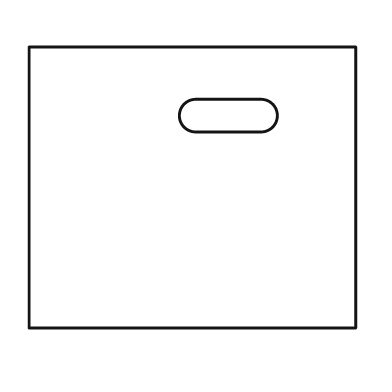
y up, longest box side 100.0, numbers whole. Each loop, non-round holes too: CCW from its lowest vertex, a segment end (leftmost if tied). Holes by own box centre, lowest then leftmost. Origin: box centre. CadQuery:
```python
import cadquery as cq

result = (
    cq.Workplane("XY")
    .moveTo(-50.0, -43.0)
    .lineTo(50.0, -43.0)
    .lineTo(50.0, 43.0)
    .lineTo(-50.0, 43.0)
    .close()
    .moveTo(1.0, 17.0)
    .lineTo(21.0, 17.0)
    .threePointArc((26.0, 22.0), (21.0, 27.0))
    .lineTo(1.0, 27.0)
    .threePointArc((-4.0, 22.0), (1.0, 17.0))
    .close()
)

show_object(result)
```